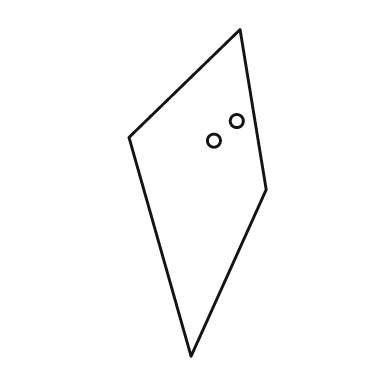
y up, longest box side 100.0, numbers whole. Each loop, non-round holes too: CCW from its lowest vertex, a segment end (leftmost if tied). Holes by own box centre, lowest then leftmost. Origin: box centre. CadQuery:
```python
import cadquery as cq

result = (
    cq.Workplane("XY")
    .moveTo(-2.0, -50.0)
    .lineTo(21.0, 1.0)
    .lineTo(13.0, 50.0)
    .lineTo(-21.0, 17.0)
    .close()
    .moveTo(5.0, 16.0)
    .circle(2.0)
    .moveTo(12.0, 22.0)
    .circle(2.0)
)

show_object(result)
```